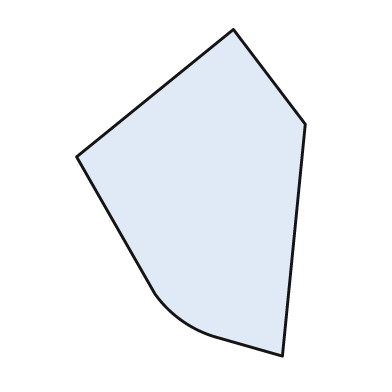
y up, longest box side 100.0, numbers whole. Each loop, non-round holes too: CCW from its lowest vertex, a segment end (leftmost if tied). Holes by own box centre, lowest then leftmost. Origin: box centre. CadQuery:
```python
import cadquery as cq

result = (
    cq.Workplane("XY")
    .moveTo(28.0, -50.0)
    .lineTo(35.0, 21.0)
    .lineTo(13.0, 50.0)
    .lineTo(-35.0, 11.0)
    .lineTo(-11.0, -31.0)
    .threePointArc((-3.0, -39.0), (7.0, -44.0))
    .close()
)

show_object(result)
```